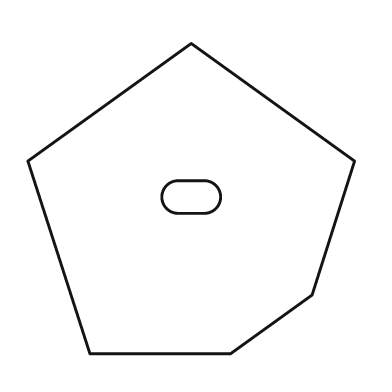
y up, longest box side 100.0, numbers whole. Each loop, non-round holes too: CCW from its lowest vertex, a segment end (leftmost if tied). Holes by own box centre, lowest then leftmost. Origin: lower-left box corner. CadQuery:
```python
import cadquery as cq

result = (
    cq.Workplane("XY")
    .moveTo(19.0, 0.0)
    .lineTo(62.0, 0.0)
    .lineTo(87.0, 18.0)
    .lineTo(100.0, 59.0)
    .lineTo(50.0, 95.0)
    .lineTo(0.0, 59.0)
    .close()
    .moveTo(46.0, 43.0)
    .lineTo(54.0, 43.0)
    .threePointArc((59.0, 48.0), (54.0, 53.0))
    .lineTo(46.0, 53.0)
    .threePointArc((41.0, 48.0), (46.0, 43.0))
    .close()
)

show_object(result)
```